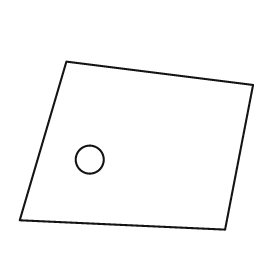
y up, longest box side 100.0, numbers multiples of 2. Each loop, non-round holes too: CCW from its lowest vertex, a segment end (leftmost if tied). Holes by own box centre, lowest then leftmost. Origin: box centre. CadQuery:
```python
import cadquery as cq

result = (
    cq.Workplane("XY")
    .moveTo(38.0, -36.0)
    .lineTo(50.0, 26.0)
    .lineTo(-30.0, 36.0)
    .lineTo(-50.0, -32.0)
    .close()
    .moveTo(-20.0, -6.0)
    .circle(6.0)
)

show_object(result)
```